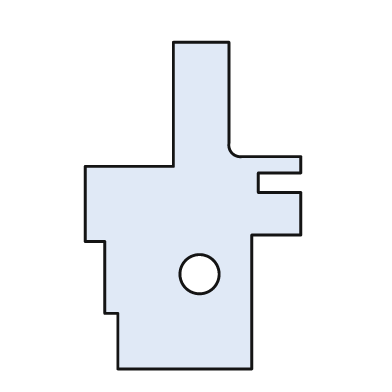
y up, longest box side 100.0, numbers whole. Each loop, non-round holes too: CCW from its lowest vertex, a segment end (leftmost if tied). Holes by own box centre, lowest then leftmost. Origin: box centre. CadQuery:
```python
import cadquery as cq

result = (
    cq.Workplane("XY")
    .moveTo(-23.0, -50.0)
    .lineTo(18.0, -50.0)
    .lineTo(18.0, -9.0)
    .lineTo(33.0, -9.0)
    .lineTo(33.0, 4.0)
    .lineTo(20.0, 4.0)
    .lineTo(20.0, 10.0)
    .lineTo(33.0, 10.0)
    .lineTo(33.0, 15.0)
    .lineTo(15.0, 15.0)
    .threePointArc((12.0, 16.0), (11.0, 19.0))
    .lineTo(11.0, 50.0)
    .lineTo(-6.0, 50.0)
    .lineTo(-6.0, 12.0)
    .lineTo(-33.0, 12.0)
    .lineTo(-33.0, -11.0)
    .lineTo(-27.0, -11.0)
    .lineTo(-27.0, -33.0)
    .lineTo(-23.0, -33.0)
    .close()
    .moveTo(2.0, -21.0)
    .circle(6.0)
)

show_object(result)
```